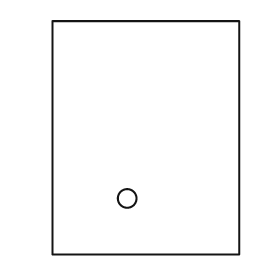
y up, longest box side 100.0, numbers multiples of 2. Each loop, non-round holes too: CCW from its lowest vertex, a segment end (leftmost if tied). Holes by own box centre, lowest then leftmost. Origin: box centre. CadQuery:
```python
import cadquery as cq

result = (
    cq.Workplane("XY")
    .moveTo(-40.0, -50.0)
    .lineTo(40.0, -50.0)
    .lineTo(40.0, 50.0)
    .lineTo(-40.0, 50.0)
    .close()
    .moveTo(-8.0, -26.0)
    .circle(4.0)
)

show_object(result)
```